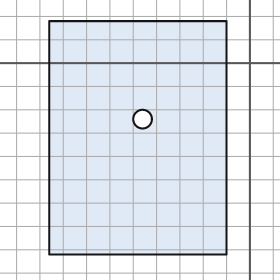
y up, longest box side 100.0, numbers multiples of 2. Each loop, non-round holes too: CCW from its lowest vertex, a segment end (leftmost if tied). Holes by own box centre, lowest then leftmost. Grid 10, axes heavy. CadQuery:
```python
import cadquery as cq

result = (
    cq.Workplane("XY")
    .moveTo(-86.0, -82.0)
    .lineTo(-10.0, -82.0)
    .lineTo(-10.0, 18.0)
    .lineTo(-86.0, 18.0)
    .close()
    .moveTo(-46.0, -24.0)
    .circle(4.0)
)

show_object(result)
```